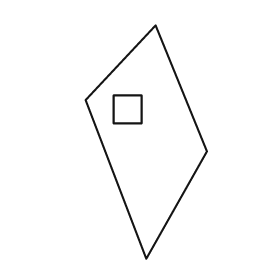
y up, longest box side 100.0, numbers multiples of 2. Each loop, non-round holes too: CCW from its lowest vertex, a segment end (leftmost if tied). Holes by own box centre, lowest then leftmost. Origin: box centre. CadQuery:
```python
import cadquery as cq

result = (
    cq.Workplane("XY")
    .moveTo(0.0, -50.0)
    .lineTo(26.0, -4.0)
    .lineTo(4.0, 50.0)
    .lineTo(-26.0, 18.0)
    .close()
    .moveTo(-14.0, 8.0)
    .lineTo(-2.0, 8.0)
    .lineTo(-2.0, 20.0)
    .lineTo(-14.0, 20.0)
    .close()
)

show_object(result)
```